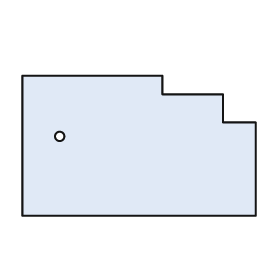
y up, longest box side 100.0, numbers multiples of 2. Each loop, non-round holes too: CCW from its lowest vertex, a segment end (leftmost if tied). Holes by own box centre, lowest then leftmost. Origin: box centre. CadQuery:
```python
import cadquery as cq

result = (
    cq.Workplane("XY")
    .moveTo(-50.0, -30.0)
    .lineTo(50.0, -30.0)
    .lineTo(50.0, 10.0)
    .lineTo(36.0, 10.0)
    .lineTo(36.0, 22.0)
    .lineTo(10.0, 22.0)
    .lineTo(10.0, 30.0)
    .lineTo(-50.0, 30.0)
    .close()
    .moveTo(-34.0, 4.0)
    .circle(2.0)
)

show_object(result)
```